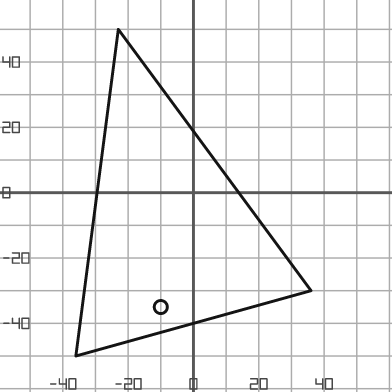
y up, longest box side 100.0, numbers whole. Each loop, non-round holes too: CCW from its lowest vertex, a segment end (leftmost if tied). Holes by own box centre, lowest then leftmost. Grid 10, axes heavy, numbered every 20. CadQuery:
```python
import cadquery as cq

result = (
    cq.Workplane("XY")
    .moveTo(-36.0, -50.0)
    .lineTo(36.0, -30.0)
    .lineTo(-23.0, 50.0)
    .close()
    .moveTo(-10.0, -35.0)
    .circle(2.0)
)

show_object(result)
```